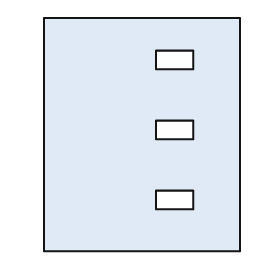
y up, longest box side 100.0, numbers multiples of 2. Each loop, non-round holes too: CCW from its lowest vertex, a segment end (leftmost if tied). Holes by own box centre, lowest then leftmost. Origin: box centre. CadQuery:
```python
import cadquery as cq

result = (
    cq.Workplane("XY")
    .moveTo(-42.0, -50.0)
    .lineTo(42.0, -50.0)
    .lineTo(42.0, 50.0)
    .lineTo(-42.0, 50.0)
    .close()
    .moveTo(6.0, -32.0)
    .lineTo(22.0, -32.0)
    .lineTo(22.0, -24.0)
    .lineTo(6.0, -24.0)
    .close()
    .moveTo(6.0, -2.0)
    .lineTo(22.0, -2.0)
    .lineTo(22.0, 6.0)
    .lineTo(6.0, 6.0)
    .close()
    .moveTo(6.0, 28.0)
    .lineTo(22.0, 28.0)
    .lineTo(22.0, 36.0)
    .lineTo(6.0, 36.0)
    .close()
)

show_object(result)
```